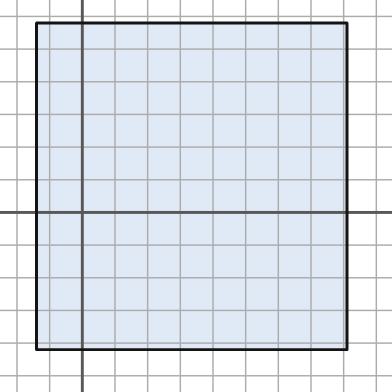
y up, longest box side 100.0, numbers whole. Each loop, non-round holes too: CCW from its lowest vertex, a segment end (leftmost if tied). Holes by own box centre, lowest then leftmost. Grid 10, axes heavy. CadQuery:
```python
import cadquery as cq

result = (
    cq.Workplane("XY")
    .moveTo(-14.0, -42.0)
    .lineTo(81.0, -42.0)
    .lineTo(81.0, 58.0)
    .lineTo(-14.0, 58.0)
    .close()
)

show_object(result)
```